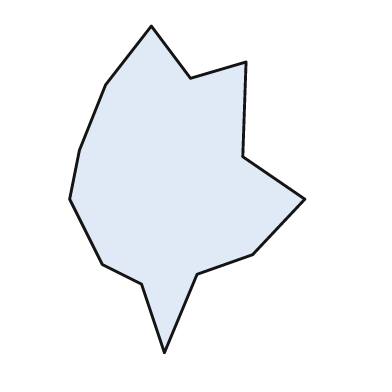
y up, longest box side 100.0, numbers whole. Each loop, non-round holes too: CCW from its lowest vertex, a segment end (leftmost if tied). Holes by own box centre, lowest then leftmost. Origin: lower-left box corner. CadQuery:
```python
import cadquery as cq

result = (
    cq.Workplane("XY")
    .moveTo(29.0, 0.0)
    .lineTo(39.0, 24.0)
    .lineTo(56.0, 30.0)
    .lineTo(72.0, 47.0)
    .lineTo(53.0, 60.0)
    .lineTo(54.0, 89.0)
    .lineTo(37.0, 84.0)
    .lineTo(25.0, 100.0)
    .lineTo(11.0, 82.0)
    .lineTo(3.0, 62.0)
    .lineTo(0.0, 47.0)
    .lineTo(10.0, 27.0)
    .lineTo(22.0, 21.0)
    .close()
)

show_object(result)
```